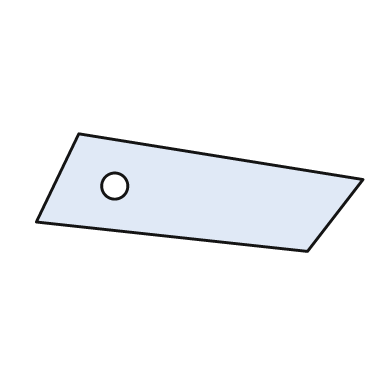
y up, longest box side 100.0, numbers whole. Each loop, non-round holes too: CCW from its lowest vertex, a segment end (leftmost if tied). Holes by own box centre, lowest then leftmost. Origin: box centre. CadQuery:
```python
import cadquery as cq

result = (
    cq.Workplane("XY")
    .moveTo(33.0, -18.0)
    .lineTo(50.0, 4.0)
    .lineTo(-37.0, 18.0)
    .lineTo(-50.0, -9.0)
    .close()
    .moveTo(-26.0, 2.0)
    .circle(4.0)
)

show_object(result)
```